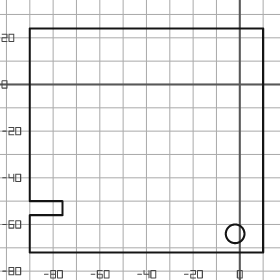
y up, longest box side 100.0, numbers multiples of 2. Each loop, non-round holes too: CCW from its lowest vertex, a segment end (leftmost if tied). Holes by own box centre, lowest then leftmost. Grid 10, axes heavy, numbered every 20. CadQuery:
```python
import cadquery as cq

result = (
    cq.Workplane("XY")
    .moveTo(-90.0, -72.0)
    .lineTo(10.0, -72.0)
    .lineTo(10.0, 24.0)
    .lineTo(-90.0, 24.0)
    .lineTo(-90.0, -50.0)
    .lineTo(-76.0, -50.0)
    .lineTo(-76.0, -56.0)
    .lineTo(-90.0, -56.0)
    .close()
    .moveTo(-2.0, -64.0)
    .circle(4.0)
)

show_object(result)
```